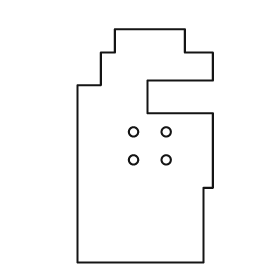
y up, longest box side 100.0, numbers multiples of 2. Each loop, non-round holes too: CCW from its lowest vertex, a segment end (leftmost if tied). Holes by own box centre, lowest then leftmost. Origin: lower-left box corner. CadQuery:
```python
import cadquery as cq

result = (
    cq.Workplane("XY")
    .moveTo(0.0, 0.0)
    .lineTo(54.0, 0.0)
    .lineTo(54.0, 32.0)
    .lineTo(58.0, 32.0)
    .lineTo(58.0, 64.0)
    .lineTo(30.0, 64.0)
    .lineTo(30.0, 78.0)
    .lineTo(58.0, 78.0)
    .lineTo(58.0, 90.0)
    .lineTo(46.0, 90.0)
    .lineTo(46.0, 100.0)
    .lineTo(16.0, 100.0)
    .lineTo(16.0, 90.0)
    .lineTo(10.0, 90.0)
    .lineTo(10.0, 76.0)
    .lineTo(0.0, 76.0)
    .close()
    .moveTo(24.0, 44.0)
    .circle(2.0)
    .moveTo(38.0, 44.0)
    .circle(2.0)
    .moveTo(24.0, 56.0)
    .circle(2.0)
    .moveTo(38.0, 56.0)
    .circle(2.0)
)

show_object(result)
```